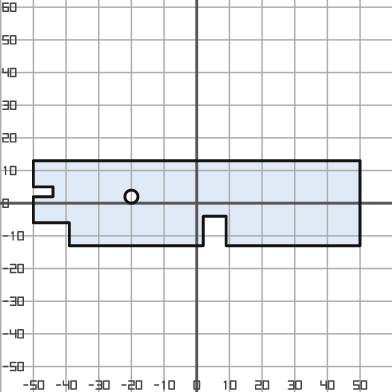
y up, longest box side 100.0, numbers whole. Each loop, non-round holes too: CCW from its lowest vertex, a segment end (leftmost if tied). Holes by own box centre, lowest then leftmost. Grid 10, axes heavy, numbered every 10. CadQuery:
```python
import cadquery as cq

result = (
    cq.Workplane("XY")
    .moveTo(-39.0, -13.0)
    .lineTo(2.0, -13.0)
    .lineTo(2.0, -4.0)
    .lineTo(9.0, -4.0)
    .lineTo(9.0, -13.0)
    .lineTo(50.0, -13.0)
    .lineTo(50.0, 13.0)
    .lineTo(-50.0, 13.0)
    .lineTo(-50.0, 5.0)
    .lineTo(-44.0, 5.0)
    .lineTo(-44.0, 2.0)
    .lineTo(-50.0, 2.0)
    .lineTo(-50.0, -6.0)
    .lineTo(-39.0, -6.0)
    .close()
    .moveTo(-20.0, 2.0)
    .circle(2.0)
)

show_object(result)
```